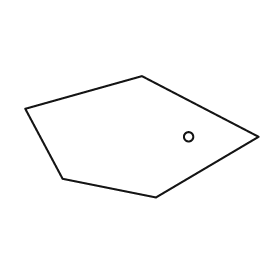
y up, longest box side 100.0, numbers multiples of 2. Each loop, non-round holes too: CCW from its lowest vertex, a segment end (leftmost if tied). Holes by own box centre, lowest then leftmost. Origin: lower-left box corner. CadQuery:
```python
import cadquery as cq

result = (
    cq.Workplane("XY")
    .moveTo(56.0, 0.0)
    .lineTo(100.0, 26.0)
    .lineTo(50.0, 52.0)
    .lineTo(0.0, 38.0)
    .lineTo(16.0, 8.0)
    .close()
    .moveTo(70.0, 26.0)
    .circle(2.0)
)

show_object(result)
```